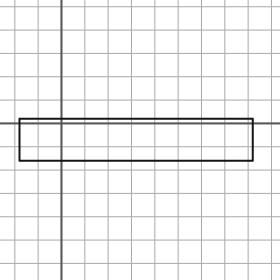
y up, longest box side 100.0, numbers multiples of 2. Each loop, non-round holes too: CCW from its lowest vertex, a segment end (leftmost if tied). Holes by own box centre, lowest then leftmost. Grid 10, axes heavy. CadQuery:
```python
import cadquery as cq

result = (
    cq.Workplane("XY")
    .moveTo(-18.0, -16.0)
    .lineTo(82.0, -16.0)
    .lineTo(82.0, 2.0)
    .lineTo(-18.0, 2.0)
    .close()
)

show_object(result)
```